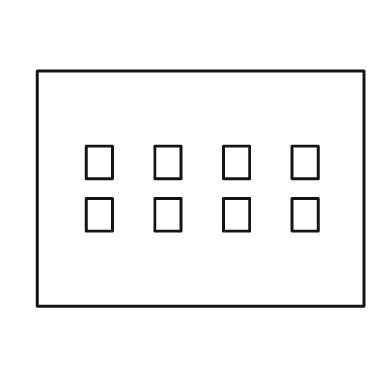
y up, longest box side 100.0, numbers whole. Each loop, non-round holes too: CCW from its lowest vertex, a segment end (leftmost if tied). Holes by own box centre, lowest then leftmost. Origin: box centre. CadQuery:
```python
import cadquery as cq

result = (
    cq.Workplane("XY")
    .moveTo(-50.0, -36.0)
    .lineTo(50.0, -36.0)
    .lineTo(50.0, 36.0)
    .lineTo(-50.0, 36.0)
    .close()
    .moveTo(-35.0, -13.0)
    .lineTo(-27.0, -13.0)
    .lineTo(-27.0, -3.0)
    .lineTo(-35.0, -3.0)
    .close()
    .moveTo(-14.0, -13.0)
    .lineTo(-6.0, -13.0)
    .lineTo(-6.0, -3.0)
    .lineTo(-14.0, -3.0)
    .close()
    .moveTo(7.0, -13.0)
    .lineTo(15.0, -13.0)
    .lineTo(15.0, -3.0)
    .lineTo(7.0, -3.0)
    .close()
    .moveTo(28.0, -13.0)
    .lineTo(36.0, -13.0)
    .lineTo(36.0, -3.0)
    .lineTo(28.0, -3.0)
    .close()
    .moveTo(-35.0, 3.0)
    .lineTo(-27.0, 3.0)
    .lineTo(-27.0, 13.0)
    .lineTo(-35.0, 13.0)
    .close()
    .moveTo(-14.0, 3.0)
    .lineTo(-6.0, 3.0)
    .lineTo(-6.0, 13.0)
    .lineTo(-14.0, 13.0)
    .close()
    .moveTo(7.0, 3.0)
    .lineTo(15.0, 3.0)
    .lineTo(15.0, 13.0)
    .lineTo(7.0, 13.0)
    .close()
    .moveTo(28.0, 3.0)
    .lineTo(36.0, 3.0)
    .lineTo(36.0, 13.0)
    .lineTo(28.0, 13.0)
    .close()
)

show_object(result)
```